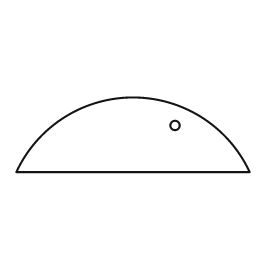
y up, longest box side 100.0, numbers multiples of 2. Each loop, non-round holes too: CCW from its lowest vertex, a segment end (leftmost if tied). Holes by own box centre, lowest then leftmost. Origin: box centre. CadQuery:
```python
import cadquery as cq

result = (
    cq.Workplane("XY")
    .moveTo(-50.0, -16.0)
    .lineTo(50.0, -16.0)
    .threePointArc((0.0, 16.0), (-50.0, -16.0))
    .close()
    .moveTo(18.0, 4.0)
    .circle(2.0)
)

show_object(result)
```